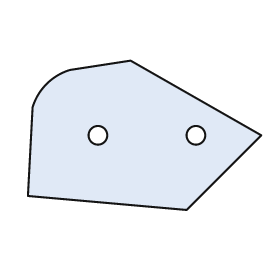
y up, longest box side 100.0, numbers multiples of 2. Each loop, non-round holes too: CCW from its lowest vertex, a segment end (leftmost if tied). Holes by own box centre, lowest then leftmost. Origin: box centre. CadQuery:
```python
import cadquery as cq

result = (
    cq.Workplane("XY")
    .moveTo(18.0, -32.0)
    .lineTo(50.0, 0.0)
    .lineTo(-6.0, 32.0)
    .lineTo(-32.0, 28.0)
    .threePointArc((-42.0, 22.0), (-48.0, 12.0))
    .lineTo(-50.0, -26.0)
    .close()
    .moveTo(-20.0, 0.0)
    .circle(4.0)
    .moveTo(22.0, 0.0)
    .circle(4.0)
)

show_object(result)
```